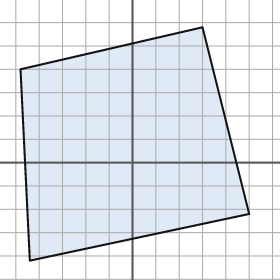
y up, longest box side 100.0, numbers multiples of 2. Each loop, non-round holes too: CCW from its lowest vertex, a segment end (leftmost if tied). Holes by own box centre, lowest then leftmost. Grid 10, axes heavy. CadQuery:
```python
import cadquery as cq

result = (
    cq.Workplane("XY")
    .moveTo(-44.0, -42.0)
    .lineTo(50.0, -22.0)
    .lineTo(30.0, 58.0)
    .lineTo(-48.0, 40.0)
    .close()
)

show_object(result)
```